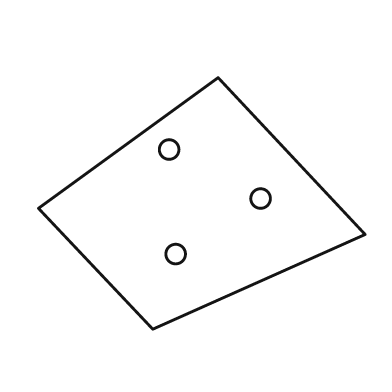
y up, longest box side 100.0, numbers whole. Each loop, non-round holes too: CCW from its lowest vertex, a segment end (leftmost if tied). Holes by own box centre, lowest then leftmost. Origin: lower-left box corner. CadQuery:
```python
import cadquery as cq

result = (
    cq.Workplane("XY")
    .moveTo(35.0, 0.0)
    .lineTo(100.0, 29.0)
    .lineTo(55.0, 77.0)
    .lineTo(0.0, 37.0)
    .close()
    .moveTo(42.0, 23.0)
    .circle(3.0)
    .moveTo(68.0, 40.0)
    .circle(3.0)
    .moveTo(40.0, 55.0)
    .circle(3.0)
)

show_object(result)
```